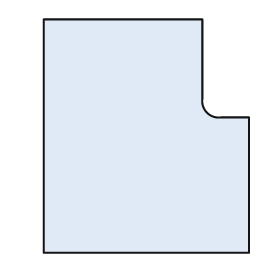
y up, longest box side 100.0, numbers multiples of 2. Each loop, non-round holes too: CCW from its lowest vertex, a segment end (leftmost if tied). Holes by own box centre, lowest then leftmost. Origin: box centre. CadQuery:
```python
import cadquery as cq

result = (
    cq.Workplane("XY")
    .moveTo(-44.0, -50.0)
    .lineTo(44.0, -50.0)
    .lineTo(44.0, 8.0)
    .lineTo(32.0, 8.0)
    .threePointArc((26.0, 10.0), (24.0, 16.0))
    .lineTo(24.0, 50.0)
    .lineTo(-44.0, 50.0)
    .close()
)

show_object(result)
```